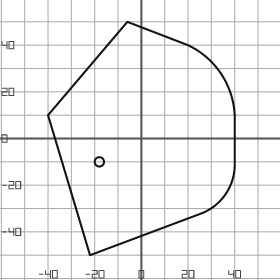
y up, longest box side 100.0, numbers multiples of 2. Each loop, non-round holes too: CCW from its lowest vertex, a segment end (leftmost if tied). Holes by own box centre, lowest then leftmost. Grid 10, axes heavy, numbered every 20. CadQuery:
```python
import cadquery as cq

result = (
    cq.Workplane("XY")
    .moveTo(-22.0, -50.0)
    .lineTo(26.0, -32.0)
    .threePointArc((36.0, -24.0), (40.0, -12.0))
    .lineTo(40.0, 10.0)
    .threePointArc((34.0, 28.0), (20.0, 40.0))
    .lineTo(-6.0, 50.0)
    .lineTo(-40.0, 10.0)
    .close()
    .moveTo(-18.0, -10.0)
    .circle(2.0)
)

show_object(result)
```